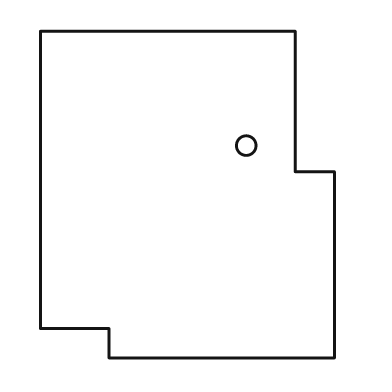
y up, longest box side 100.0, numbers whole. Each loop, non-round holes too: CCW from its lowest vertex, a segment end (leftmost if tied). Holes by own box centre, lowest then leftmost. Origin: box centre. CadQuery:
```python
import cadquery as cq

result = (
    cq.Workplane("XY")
    .moveTo(-24.0, -50.0)
    .lineTo(45.0, -50.0)
    .lineTo(45.0, 7.0)
    .lineTo(33.0, 7.0)
    .lineTo(33.0, 50.0)
    .lineTo(-45.0, 50.0)
    .lineTo(-45.0, -41.0)
    .lineTo(-24.0, -41.0)
    .close()
    .moveTo(18.0, 15.0)
    .circle(3.0)
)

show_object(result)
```